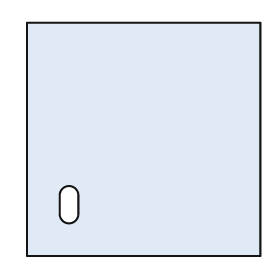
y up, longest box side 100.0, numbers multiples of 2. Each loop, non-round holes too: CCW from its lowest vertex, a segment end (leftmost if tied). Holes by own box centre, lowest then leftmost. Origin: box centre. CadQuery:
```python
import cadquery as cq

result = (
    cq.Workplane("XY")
    .moveTo(-50.0, -50.0)
    .lineTo(50.0, -50.0)
    .lineTo(50.0, 50.0)
    .lineTo(-50.0, 50.0)
    .close()
    .moveTo(-36.0, -32.0)
    .threePointArc((-32.0, -36.0), (-28.0, -32.0))
    .lineTo(-28.0, -24.0)
    .threePointArc((-32.0, -20.0), (-36.0, -24.0))
    .close()
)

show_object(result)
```